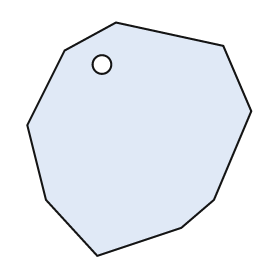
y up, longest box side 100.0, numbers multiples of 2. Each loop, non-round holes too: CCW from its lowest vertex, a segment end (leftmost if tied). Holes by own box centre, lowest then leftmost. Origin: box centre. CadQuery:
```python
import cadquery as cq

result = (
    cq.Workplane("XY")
    .moveTo(-18.0, -50.0)
    .lineTo(18.0, -38.0)
    .lineTo(32.0, -26.0)
    .lineTo(48.0, 12.0)
    .lineTo(36.0, 40.0)
    .lineTo(-10.0, 50.0)
    .lineTo(-32.0, 38.0)
    .lineTo(-48.0, 6.0)
    .lineTo(-40.0, -26.0)
    .close()
    .moveTo(-16.0, 32.0)
    .circle(4.0)
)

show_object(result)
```